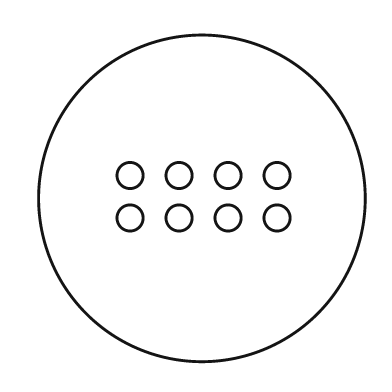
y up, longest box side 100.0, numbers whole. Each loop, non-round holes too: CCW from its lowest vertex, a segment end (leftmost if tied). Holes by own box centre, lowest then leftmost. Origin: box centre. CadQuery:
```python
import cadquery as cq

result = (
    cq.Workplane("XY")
    .moveTo(0.0, 0.0)
    .circle(50.0)
    .moveTo(-22.0, -6.0)
    .circle(4.0)
    .moveTo(-7.0, -6.0)
    .circle(4.0)
    .moveTo(8.0, -6.0)
    .circle(4.0)
    .moveTo(23.0, -6.0)
    .circle(4.0)
    .moveTo(-22.0, 7.0)
    .circle(4.0)
    .moveTo(-7.0, 7.0)
    .circle(4.0)
    .moveTo(8.0, 7.0)
    .circle(4.0)
    .moveTo(23.0, 7.0)
    .circle(4.0)
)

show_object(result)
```